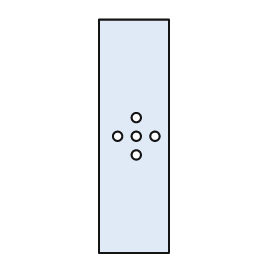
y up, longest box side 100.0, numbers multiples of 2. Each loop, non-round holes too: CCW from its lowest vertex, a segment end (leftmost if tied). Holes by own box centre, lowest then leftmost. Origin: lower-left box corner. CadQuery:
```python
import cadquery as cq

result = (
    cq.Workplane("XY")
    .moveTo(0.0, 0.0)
    .lineTo(30.0, 0.0)
    .lineTo(30.0, 100.0)
    .lineTo(0.0, 100.0)
    .close()
    .moveTo(16.0, 42.0)
    .circle(2.0)
    .moveTo(8.0, 50.0)
    .circle(2.0)
    .moveTo(16.0, 50.0)
    .circle(2.0)
    .moveTo(24.0, 50.0)
    .circle(2.0)
    .moveTo(16.0, 58.0)
    .circle(2.0)
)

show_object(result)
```